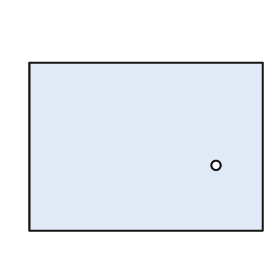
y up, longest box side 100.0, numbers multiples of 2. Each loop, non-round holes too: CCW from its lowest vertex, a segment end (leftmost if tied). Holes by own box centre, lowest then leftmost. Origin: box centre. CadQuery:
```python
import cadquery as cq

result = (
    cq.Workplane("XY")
    .moveTo(-50.0, -36.0)
    .lineTo(50.0, -36.0)
    .lineTo(50.0, 36.0)
    .lineTo(-50.0, 36.0)
    .close()
    .moveTo(30.0, -8.0)
    .circle(2.0)
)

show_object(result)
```